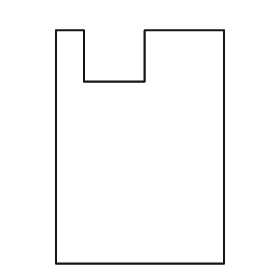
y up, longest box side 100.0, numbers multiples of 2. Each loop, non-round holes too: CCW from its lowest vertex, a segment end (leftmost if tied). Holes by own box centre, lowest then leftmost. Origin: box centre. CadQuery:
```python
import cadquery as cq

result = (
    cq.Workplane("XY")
    .moveTo(-36.0, -50.0)
    .lineTo(36.0, -50.0)
    .lineTo(36.0, 50.0)
    .lineTo(2.0, 50.0)
    .lineTo(2.0, 28.0)
    .lineTo(-24.0, 28.0)
    .lineTo(-24.0, 50.0)
    .lineTo(-36.0, 50.0)
    .close()
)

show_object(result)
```